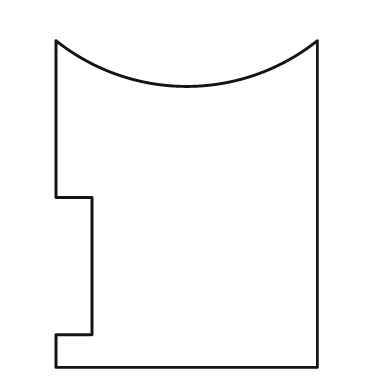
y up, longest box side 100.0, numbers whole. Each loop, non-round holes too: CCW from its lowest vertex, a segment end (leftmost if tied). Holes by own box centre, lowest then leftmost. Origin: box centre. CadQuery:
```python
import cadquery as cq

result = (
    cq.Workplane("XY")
    .moveTo(-40.0, -50.0)
    .lineTo(40.0, -50.0)
    .lineTo(40.0, 50.0)
    .threePointArc((0.0, 36.0), (-40.0, 50.0))
    .lineTo(-40.0, 2.0)
    .lineTo(-29.0, 2.0)
    .lineTo(-29.0, -40.0)
    .lineTo(-40.0, -40.0)
    .close()
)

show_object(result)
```